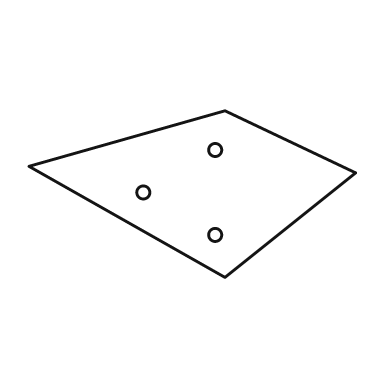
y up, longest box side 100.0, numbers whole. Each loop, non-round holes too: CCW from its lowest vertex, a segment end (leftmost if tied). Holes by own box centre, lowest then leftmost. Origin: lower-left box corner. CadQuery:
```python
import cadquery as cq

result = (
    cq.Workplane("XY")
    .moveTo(60.0, 0.0)
    .lineTo(100.0, 32.0)
    .lineTo(60.0, 51.0)
    .lineTo(0.0, 34.0)
    .close()
    .moveTo(57.0, 13.0)
    .circle(2.0)
    .moveTo(35.0, 26.0)
    .circle(2.0)
    .moveTo(57.0, 39.0)
    .circle(2.0)
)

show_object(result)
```